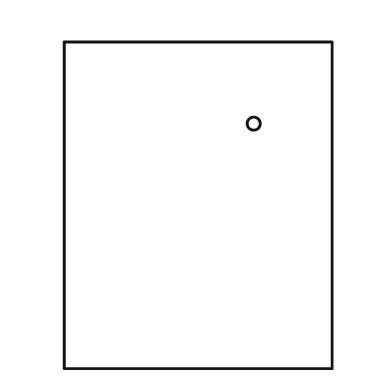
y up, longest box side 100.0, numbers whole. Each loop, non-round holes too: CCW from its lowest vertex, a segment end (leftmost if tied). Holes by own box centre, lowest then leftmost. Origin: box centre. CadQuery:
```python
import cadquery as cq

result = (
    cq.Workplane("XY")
    .moveTo(-41.0, -50.0)
    .lineTo(41.0, -50.0)
    .lineTo(41.0, 50.0)
    .lineTo(-41.0, 50.0)
    .close()
    .moveTo(17.0, 25.0)
    .circle(2.0)
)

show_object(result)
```